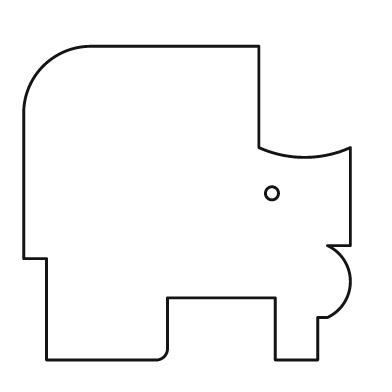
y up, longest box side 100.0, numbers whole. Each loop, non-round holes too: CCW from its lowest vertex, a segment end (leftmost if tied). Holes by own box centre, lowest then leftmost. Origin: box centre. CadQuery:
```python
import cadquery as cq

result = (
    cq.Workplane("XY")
    .moveTo(-43.0, -48.0)
    .lineTo(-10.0, -48.0)
    .threePointArc((-7.0, -47.0), (-6.0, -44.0))
    .lineTo(-6.0, -29.0)
    .lineTo(27.0, -29.0)
    .lineTo(27.0, -48.0)
    .lineTo(40.0, -48.0)
    .lineTo(40.0, -35.0)
    .lineTo(43.0, -35.0)
    .threePointArc((50.0, -24.0), (43.0, -13.0))
    .lineTo(50.0, -13.0)
    .lineTo(50.0, 17.0)
    .threePointArc((36.0, 14.0), (22.0, 17.0))
    .lineTo(22.0, 48.0)
    .lineTo(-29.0, 48.0)
    .threePointArc((-44.0, 42.0), (-50.0, 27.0))
    .lineTo(-50.0, -17.0)
    .lineTo(-43.0, -17.0)
    .close()
    .moveTo(26.0, 3.0)
    .circle(2.0)
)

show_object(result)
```